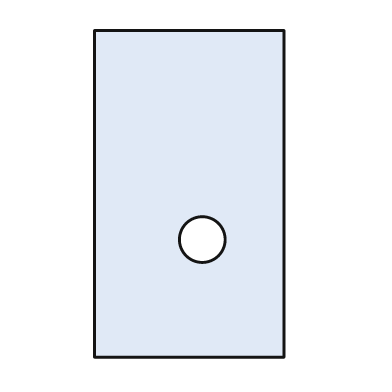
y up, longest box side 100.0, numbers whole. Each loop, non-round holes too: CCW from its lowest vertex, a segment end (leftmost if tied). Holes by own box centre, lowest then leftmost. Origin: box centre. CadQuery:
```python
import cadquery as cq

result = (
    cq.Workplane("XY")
    .moveTo(-29.0, -50.0)
    .lineTo(29.0, -50.0)
    .lineTo(29.0, 50.0)
    .lineTo(-29.0, 50.0)
    .close()
    .moveTo(4.0, -14.0)
    .circle(7.0)
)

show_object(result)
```